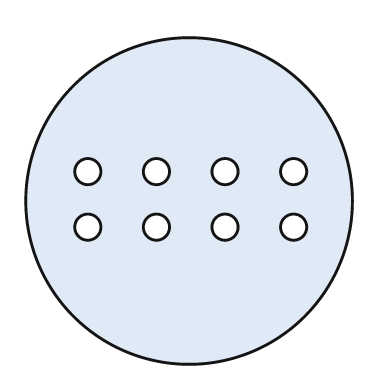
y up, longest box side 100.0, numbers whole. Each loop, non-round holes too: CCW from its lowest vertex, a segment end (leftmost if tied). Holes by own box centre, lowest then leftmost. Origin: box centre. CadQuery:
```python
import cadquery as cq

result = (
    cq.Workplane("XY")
    .moveTo(0.0, 0.0)
    .circle(50.0)
    .moveTo(-31.0, -8.0)
    .circle(4.0)
    .moveTo(-10.0, -8.0)
    .circle(4.0)
    .moveTo(11.0, -8.0)
    .circle(4.0)
    .moveTo(32.0, -8.0)
    .circle(4.0)
    .moveTo(-31.0, 9.0)
    .circle(4.0)
    .moveTo(-10.0, 9.0)
    .circle(4.0)
    .moveTo(11.0, 9.0)
    .circle(4.0)
    .moveTo(32.0, 9.0)
    .circle(4.0)
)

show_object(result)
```